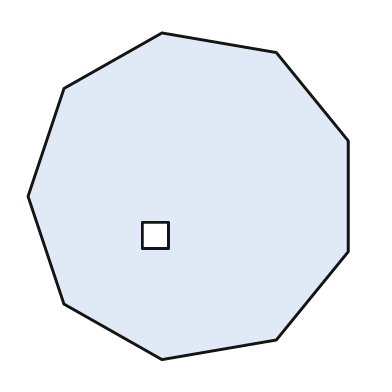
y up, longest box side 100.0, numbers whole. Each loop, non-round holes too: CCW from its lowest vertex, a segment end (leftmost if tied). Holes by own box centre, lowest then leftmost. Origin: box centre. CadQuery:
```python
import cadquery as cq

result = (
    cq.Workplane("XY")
    .moveTo(-8.0, -50.0)
    .lineTo(27.0, -44.0)
    .lineTo(49.0, -17.0)
    .lineTo(49.0, 17.0)
    .lineTo(27.0, 44.0)
    .lineTo(-8.0, 50.0)
    .lineTo(-38.0, 33.0)
    .lineTo(-49.0, 0.0)
    .lineTo(-38.0, -33.0)
    .close()
    .moveTo(-14.0, -16.0)
    .lineTo(-6.0, -16.0)
    .lineTo(-6.0, -8.0)
    .lineTo(-14.0, -8.0)
    .close()
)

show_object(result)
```